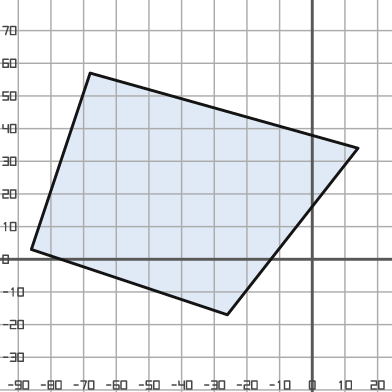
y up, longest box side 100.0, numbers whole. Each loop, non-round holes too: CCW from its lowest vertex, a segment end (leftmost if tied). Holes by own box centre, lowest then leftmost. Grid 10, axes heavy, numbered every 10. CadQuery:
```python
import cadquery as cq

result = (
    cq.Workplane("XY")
    .moveTo(-26.0, -17.0)
    .lineTo(14.0, 34.0)
    .lineTo(-68.0, 57.0)
    .lineTo(-86.0, 3.0)
    .close()
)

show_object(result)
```